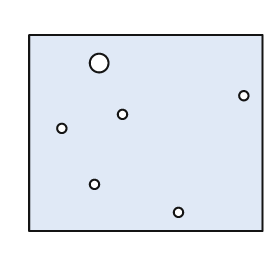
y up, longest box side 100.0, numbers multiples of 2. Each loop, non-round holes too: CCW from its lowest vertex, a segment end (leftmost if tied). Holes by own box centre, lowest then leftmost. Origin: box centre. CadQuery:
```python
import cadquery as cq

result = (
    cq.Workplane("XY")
    .moveTo(-50.0, -42.0)
    .lineTo(50.0, -42.0)
    .lineTo(50.0, 42.0)
    .lineTo(-50.0, 42.0)
    .close()
    .moveTo(14.0, -34.0)
    .circle(2.0)
    .moveTo(-22.0, -22.0)
    .circle(2.0)
    .moveTo(-36.0, 2.0)
    .circle(2.0)
    .moveTo(-10.0, 8.0)
    .circle(2.0)
    .moveTo(42.0, 16.0)
    .circle(2.0)
    .moveTo(-20.0, 30.0)
    .circle(4.0)
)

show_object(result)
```